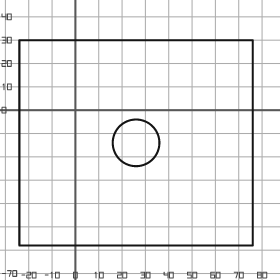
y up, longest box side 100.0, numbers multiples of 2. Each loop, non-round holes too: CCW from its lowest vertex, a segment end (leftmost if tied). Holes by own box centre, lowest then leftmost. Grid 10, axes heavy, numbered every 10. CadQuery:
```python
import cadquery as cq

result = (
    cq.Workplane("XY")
    .moveTo(-24.0, -58.0)
    .lineTo(76.0, -58.0)
    .lineTo(76.0, 30.0)
    .lineTo(-24.0, 30.0)
    .close()
    .moveTo(26.0, -14.0)
    .circle(10.0)
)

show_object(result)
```